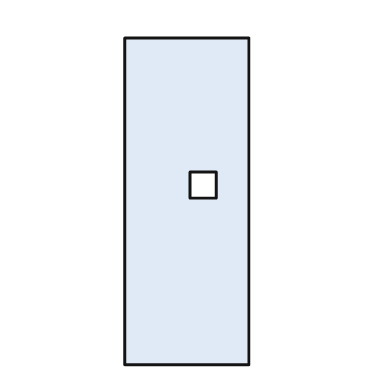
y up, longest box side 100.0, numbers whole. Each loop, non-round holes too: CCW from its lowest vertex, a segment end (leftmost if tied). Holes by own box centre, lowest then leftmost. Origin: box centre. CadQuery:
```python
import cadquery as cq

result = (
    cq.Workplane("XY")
    .moveTo(-19.0, -50.0)
    .lineTo(19.0, -50.0)
    .lineTo(19.0, 50.0)
    .lineTo(-19.0, 50.0)
    .close()
    .moveTo(1.0, 1.0)
    .lineTo(9.0, 1.0)
    .lineTo(9.0, 9.0)
    .lineTo(1.0, 9.0)
    .close()
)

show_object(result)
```